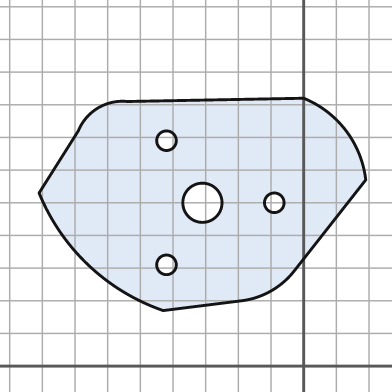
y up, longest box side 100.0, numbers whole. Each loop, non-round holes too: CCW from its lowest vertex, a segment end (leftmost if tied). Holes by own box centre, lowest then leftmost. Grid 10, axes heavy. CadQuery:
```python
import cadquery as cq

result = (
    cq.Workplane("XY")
    .moveTo(-43.0, 17.0)
    .lineTo(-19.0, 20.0)
    .threePointArc((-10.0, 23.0), (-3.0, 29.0))
    .lineTo(19.0, 57.0)
    .threePointArc((13.0, 72.0), (0.0, 82.0))
    .lineTo(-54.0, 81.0)
    .threePointArc((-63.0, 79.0), (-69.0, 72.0))
    .lineTo(-81.0, 53.0)
    .threePointArc((-66.0, 31.0), (-43.0, 17.0))
    .close()
    .moveTo(-42.0, 31.0)
    .circle(3.0)
    .moveTo(-31.0, 50.0)
    .circle(6.0)
    .moveTo(-9.0, 50.0)
    .circle(3.0)
    .moveTo(-42.0, 69.0)
    .circle(3.0)
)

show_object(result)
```